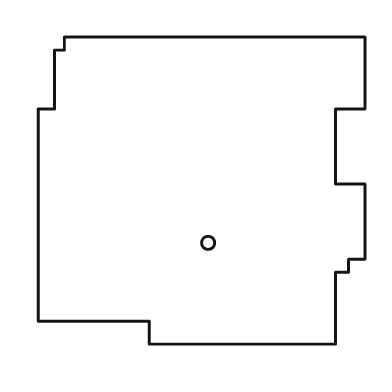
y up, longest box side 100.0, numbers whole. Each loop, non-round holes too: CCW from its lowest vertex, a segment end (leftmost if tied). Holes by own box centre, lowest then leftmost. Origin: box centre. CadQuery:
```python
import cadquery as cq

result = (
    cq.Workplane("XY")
    .moveTo(-16.0, -47.0)
    .lineTo(41.0, -47.0)
    .lineTo(41.0, -25.0)
    .lineTo(45.0, -25.0)
    .lineTo(45.0, -21.0)
    .lineTo(50.0, -21.0)
    .lineTo(50.0, 2.0)
    .lineTo(41.0, 2.0)
    .lineTo(41.0, 25.0)
    .lineTo(50.0, 25.0)
    .lineTo(50.0, 47.0)
    .lineTo(-42.0, 47.0)
    .lineTo(-42.0, 43.0)
    .lineTo(-45.0, 43.0)
    .lineTo(-45.0, 25.0)
    .lineTo(-50.0, 25.0)
    .lineTo(-50.0, -40.0)
    .lineTo(-16.0, -40.0)
    .close()
    .moveTo(2.0, -16.0)
    .circle(2.0)
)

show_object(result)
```